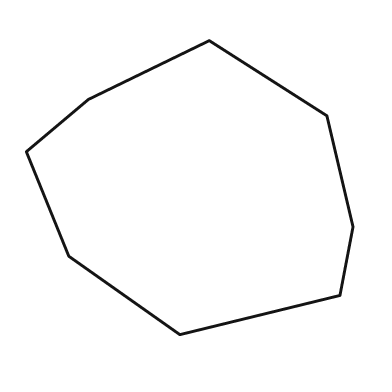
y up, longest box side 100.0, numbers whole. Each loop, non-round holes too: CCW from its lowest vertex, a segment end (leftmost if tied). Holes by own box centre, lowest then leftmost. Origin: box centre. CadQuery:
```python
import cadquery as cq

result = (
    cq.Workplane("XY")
    .moveTo(-3.0, -45.0)
    .lineTo(46.0, -33.0)
    .lineTo(50.0, -12.0)
    .lineTo(42.0, 22.0)
    .lineTo(6.0, 45.0)
    .lineTo(-31.0, 27.0)
    .lineTo(-50.0, 11.0)
    .lineTo(-37.0, -21.0)
    .close()
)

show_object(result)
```